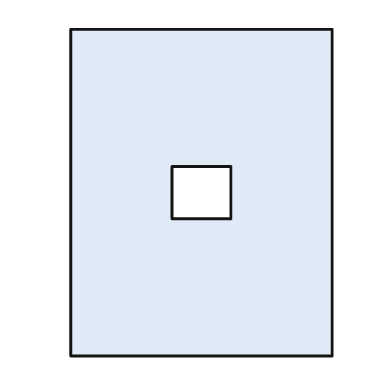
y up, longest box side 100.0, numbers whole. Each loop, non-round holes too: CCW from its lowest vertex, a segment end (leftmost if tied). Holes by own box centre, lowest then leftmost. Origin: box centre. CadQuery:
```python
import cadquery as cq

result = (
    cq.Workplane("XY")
    .moveTo(-40.0, -50.0)
    .lineTo(40.0, -50.0)
    .lineTo(40.0, 50.0)
    .lineTo(-40.0, 50.0)
    .close()
    .moveTo(-9.0, -8.0)
    .lineTo(9.0, -8.0)
    .lineTo(9.0, 8.0)
    .lineTo(-9.0, 8.0)
    .close()
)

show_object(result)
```